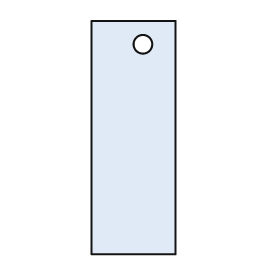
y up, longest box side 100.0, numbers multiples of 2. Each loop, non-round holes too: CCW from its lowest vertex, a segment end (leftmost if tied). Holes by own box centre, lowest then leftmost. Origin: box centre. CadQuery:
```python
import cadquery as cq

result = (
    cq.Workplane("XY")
    .moveTo(-18.0, -50.0)
    .lineTo(18.0, -50.0)
    .lineTo(18.0, 50.0)
    .lineTo(-18.0, 50.0)
    .close()
    .moveTo(4.0, 40.0)
    .circle(4.0)
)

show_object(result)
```